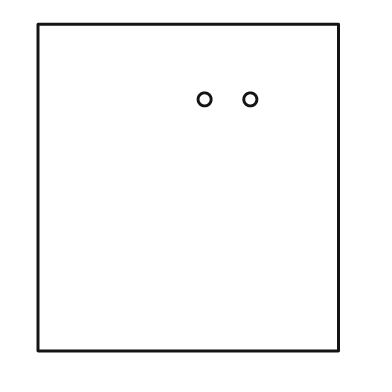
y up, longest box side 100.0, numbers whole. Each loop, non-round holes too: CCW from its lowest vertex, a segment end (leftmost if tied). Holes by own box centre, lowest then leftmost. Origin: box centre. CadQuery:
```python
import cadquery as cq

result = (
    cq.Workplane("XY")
    .moveTo(-46.0, -50.0)
    .lineTo(46.0, -50.0)
    .lineTo(46.0, 50.0)
    .lineTo(-46.0, 50.0)
    .close()
    .moveTo(5.0, 27.0)
    .circle(2.0)
    .moveTo(19.0, 27.0)
    .circle(2.0)
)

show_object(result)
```